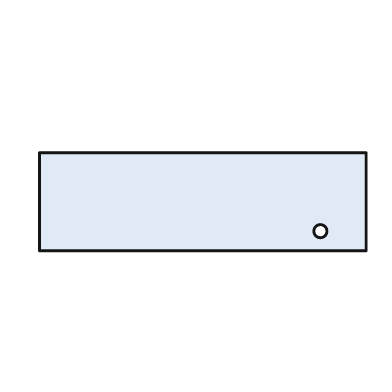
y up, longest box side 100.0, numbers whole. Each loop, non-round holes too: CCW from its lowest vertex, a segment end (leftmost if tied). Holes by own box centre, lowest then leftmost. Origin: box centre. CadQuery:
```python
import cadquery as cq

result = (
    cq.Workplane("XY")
    .moveTo(-50.0, -15.0)
    .lineTo(50.0, -15.0)
    .lineTo(50.0, 15.0)
    .lineTo(-50.0, 15.0)
    .close()
    .moveTo(36.0, -9.0)
    .circle(2.0)
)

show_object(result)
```